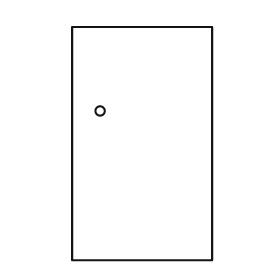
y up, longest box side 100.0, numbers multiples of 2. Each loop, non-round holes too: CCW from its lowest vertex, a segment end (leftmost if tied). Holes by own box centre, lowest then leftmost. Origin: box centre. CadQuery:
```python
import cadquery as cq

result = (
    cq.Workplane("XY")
    .moveTo(-30.0, -50.0)
    .lineTo(30.0, -50.0)
    .lineTo(30.0, 50.0)
    .lineTo(-30.0, 50.0)
    .close()
    .moveTo(-18.0, 14.0)
    .circle(2.0)
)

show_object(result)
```